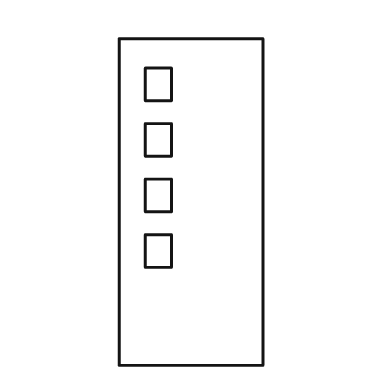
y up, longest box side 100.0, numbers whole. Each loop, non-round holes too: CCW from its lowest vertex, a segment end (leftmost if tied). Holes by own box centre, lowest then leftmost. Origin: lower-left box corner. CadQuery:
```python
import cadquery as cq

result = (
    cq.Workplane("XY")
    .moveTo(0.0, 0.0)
    .lineTo(44.0, 0.0)
    .lineTo(44.0, 100.0)
    .lineTo(0.0, 100.0)
    .close()
    .moveTo(8.0, 30.0)
    .lineTo(16.0, 30.0)
    .lineTo(16.0, 40.0)
    .lineTo(8.0, 40.0)
    .close()
    .moveTo(8.0, 47.0)
    .lineTo(16.0, 47.0)
    .lineTo(16.0, 57.0)
    .lineTo(8.0, 57.0)
    .close()
    .moveTo(8.0, 64.0)
    .lineTo(16.0, 64.0)
    .lineTo(16.0, 74.0)
    .lineTo(8.0, 74.0)
    .close()
    .moveTo(8.0, 81.0)
    .lineTo(16.0, 81.0)
    .lineTo(16.0, 91.0)
    .lineTo(8.0, 91.0)
    .close()
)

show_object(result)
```